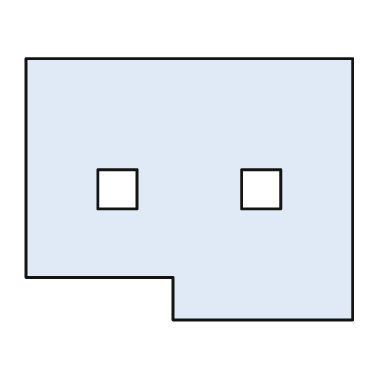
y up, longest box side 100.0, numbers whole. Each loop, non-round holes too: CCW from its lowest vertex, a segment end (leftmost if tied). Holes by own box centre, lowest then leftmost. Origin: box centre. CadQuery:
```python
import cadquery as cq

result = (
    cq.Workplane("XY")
    .moveTo(-5.0, -40.0)
    .lineTo(50.0, -40.0)
    .lineTo(50.0, 40.0)
    .lineTo(-50.0, 40.0)
    .lineTo(-50.0, -27.0)
    .lineTo(-5.0, -27.0)
    .close()
    .moveTo(-28.0, -6.0)
    .lineTo(-16.0, -6.0)
    .lineTo(-16.0, 6.0)
    .lineTo(-28.0, 6.0)
    .close()
    .moveTo(16.0, -6.0)
    .lineTo(28.0, -6.0)
    .lineTo(28.0, 6.0)
    .lineTo(16.0, 6.0)
    .close()
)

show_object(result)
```